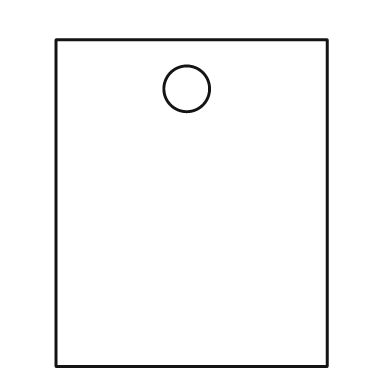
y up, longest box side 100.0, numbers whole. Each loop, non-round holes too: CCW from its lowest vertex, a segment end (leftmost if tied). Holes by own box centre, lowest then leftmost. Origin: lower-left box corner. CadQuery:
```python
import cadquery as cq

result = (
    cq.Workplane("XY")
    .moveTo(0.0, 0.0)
    .lineTo(83.0, 0.0)
    .lineTo(83.0, 100.0)
    .lineTo(0.0, 100.0)
    .close()
    .moveTo(40.0, 85.0)
    .circle(7.0)
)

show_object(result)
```